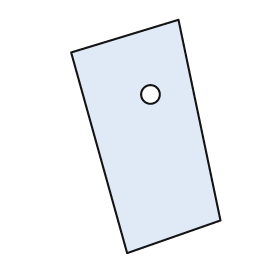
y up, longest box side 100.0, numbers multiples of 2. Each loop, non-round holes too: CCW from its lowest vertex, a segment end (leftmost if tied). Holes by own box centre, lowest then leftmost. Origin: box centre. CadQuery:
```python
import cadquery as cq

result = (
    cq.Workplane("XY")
    .moveTo(-8.0, -50.0)
    .lineTo(32.0, -36.0)
    .lineTo(14.0, 50.0)
    .lineTo(-32.0, 36.0)
    .close()
    .moveTo(2.0, 18.0)
    .circle(4.0)
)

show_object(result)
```